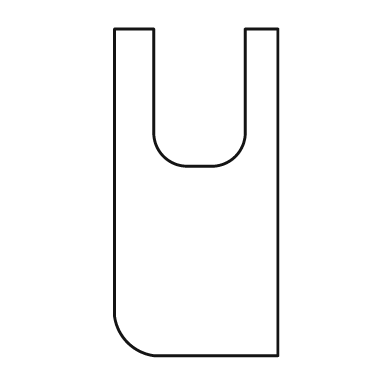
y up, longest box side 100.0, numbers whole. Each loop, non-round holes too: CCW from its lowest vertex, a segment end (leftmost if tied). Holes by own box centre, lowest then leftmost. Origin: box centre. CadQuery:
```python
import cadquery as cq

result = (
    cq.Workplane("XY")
    .moveTo(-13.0, -50.0)
    .lineTo(25.0, -50.0)
    .lineTo(25.0, 50.0)
    .lineTo(15.0, 50.0)
    .lineTo(15.0, 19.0)
    .threePointArc((12.0, 11.0), (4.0, 8.0))
    .lineTo(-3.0, 8.0)
    .threePointArc((-10.0, 11.0), (-13.0, 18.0))
    .lineTo(-13.0, 50.0)
    .lineTo(-25.0, 50.0)
    .lineTo(-25.0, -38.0)
    .threePointArc((-21.0, -46.0), (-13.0, -50.0))
    .close()
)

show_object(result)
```